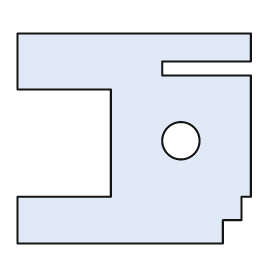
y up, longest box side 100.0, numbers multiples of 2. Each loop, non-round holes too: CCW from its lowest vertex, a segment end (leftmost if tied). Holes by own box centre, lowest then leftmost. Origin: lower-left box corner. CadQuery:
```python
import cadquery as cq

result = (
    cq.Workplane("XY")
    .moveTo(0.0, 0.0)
    .lineTo(88.0, 0.0)
    .lineTo(88.0, 10.0)
    .lineTo(96.0, 10.0)
    .lineTo(96.0, 20.0)
    .lineTo(100.0, 20.0)
    .lineTo(100.0, 72.0)
    .lineTo(62.0, 72.0)
    .lineTo(62.0, 78.0)
    .lineTo(100.0, 78.0)
    .lineTo(100.0, 90.0)
    .lineTo(0.0, 90.0)
    .lineTo(0.0, 66.0)
    .lineTo(40.0, 66.0)
    .lineTo(40.0, 20.0)
    .lineTo(0.0, 20.0)
    .close()
    .moveTo(70.0, 44.0)
    .circle(8.0)
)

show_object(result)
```